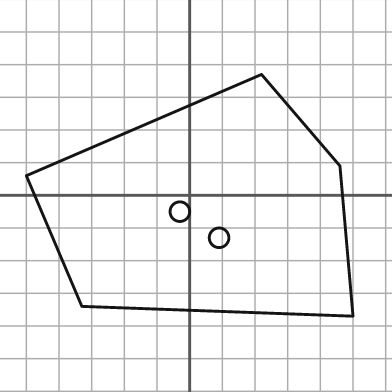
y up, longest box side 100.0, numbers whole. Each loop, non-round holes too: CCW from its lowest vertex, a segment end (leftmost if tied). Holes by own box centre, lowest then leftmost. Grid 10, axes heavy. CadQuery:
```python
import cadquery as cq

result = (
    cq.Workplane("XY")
    .moveTo(50.0, -37.0)
    .lineTo(46.0, 9.0)
    .lineTo(22.0, 37.0)
    .lineTo(-50.0, 6.0)
    .lineTo(-33.0, -34.0)
    .close()
    .moveTo(9.0, -13.0)
    .circle(3.0)
    .moveTo(-3.0, -5.0)
    .circle(3.0)
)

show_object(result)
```